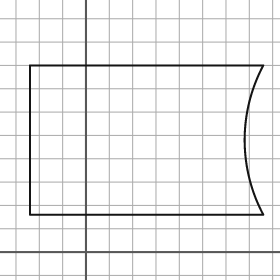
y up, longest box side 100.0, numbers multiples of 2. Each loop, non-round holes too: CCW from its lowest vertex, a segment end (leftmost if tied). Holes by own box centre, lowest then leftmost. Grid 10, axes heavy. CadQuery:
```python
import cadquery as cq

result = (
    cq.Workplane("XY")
    .moveTo(-24.0, 16.0)
    .lineTo(76.0, 16.0)
    .threePointArc((68.0, 48.0), (76.0, 80.0))
    .lineTo(-24.0, 80.0)
    .close()
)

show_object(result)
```